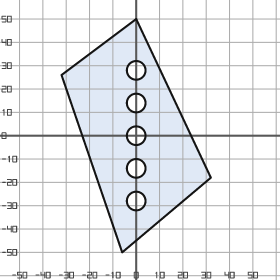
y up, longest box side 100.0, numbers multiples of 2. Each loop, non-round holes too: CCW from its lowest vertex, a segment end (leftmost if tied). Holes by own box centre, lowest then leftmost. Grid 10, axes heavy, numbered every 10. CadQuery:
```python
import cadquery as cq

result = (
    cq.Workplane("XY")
    .moveTo(-6.0, -50.0)
    .lineTo(32.0, -18.0)
    .lineTo(0.0, 50.0)
    .lineTo(-32.0, 26.0)
    .close()
    .moveTo(0.0, -28.0)
    .circle(4.0)
    .moveTo(0.0, -14.0)
    .circle(4.0)
    .moveTo(0.0, 0.0)
    .circle(4.0)
    .moveTo(0.0, 14.0)
    .circle(4.0)
    .moveTo(0.0, 28.0)
    .circle(4.0)
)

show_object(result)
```